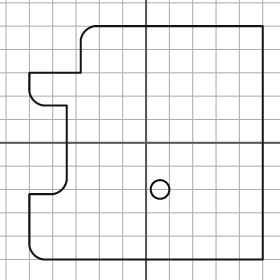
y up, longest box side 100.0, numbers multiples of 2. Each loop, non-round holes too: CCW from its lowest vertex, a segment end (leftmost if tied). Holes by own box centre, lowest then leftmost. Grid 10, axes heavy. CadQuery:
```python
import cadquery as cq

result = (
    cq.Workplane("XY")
    .moveTo(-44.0, -50.0)
    .lineTo(50.0, -50.0)
    .lineTo(50.0, 50.0)
    .lineTo(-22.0, 50.0)
    .threePointArc((-26.0, 48.0), (-28.0, 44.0))
    .lineTo(-28.0, 30.0)
    .lineTo(-50.0, 30.0)
    .lineTo(-50.0, 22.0)
    .threePointArc((-48.0, 18.0), (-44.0, 16.0))
    .lineTo(-34.0, 16.0)
    .lineTo(-34.0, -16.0)
    .threePointArc((-36.0, -20.0), (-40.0, -22.0))
    .lineTo(-50.0, -22.0)
    .lineTo(-50.0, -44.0)
    .threePointArc((-48.0, -48.0), (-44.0, -50.0))
    .close()
    .moveTo(6.0, -20.0)
    .circle(4.0)
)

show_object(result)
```